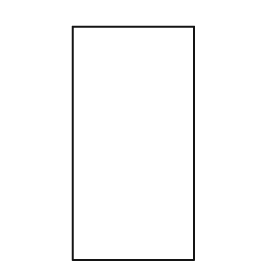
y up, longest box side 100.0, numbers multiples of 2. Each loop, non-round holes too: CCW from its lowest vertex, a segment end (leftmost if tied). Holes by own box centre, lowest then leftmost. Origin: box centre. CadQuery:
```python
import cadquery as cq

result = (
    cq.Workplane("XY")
    .moveTo(-26.0, -50.0)
    .lineTo(26.0, -50.0)
    .lineTo(26.0, 50.0)
    .lineTo(-26.0, 50.0)
    .close()
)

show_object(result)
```